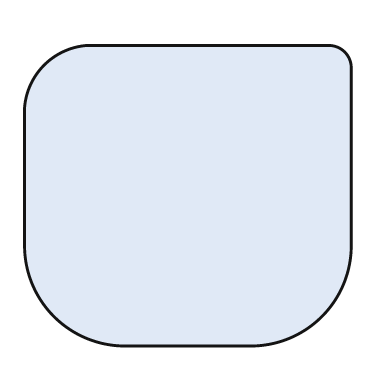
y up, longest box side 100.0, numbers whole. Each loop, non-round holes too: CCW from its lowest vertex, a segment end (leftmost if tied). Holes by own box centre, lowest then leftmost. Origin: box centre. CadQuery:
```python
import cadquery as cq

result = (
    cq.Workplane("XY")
    .moveTo(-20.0, -46.0)
    .lineTo(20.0, -46.0)
    .threePointArc((41.0, -37.0), (50.0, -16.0))
    .lineTo(50.0, 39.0)
    .threePointArc((48.0, 44.0), (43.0, 46.0))
    .lineTo(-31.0, 46.0)
    .threePointArc((-44.0, 40.0), (-50.0, 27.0))
    .lineTo(-50.0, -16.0)
    .threePointArc((-41.0, -37.0), (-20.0, -46.0))
    .close()
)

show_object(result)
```